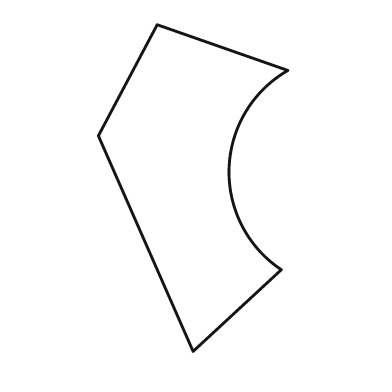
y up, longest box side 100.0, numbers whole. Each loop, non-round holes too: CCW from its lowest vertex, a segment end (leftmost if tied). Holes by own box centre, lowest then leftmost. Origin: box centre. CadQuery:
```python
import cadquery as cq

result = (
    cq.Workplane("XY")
    .moveTo(0.0, -50.0)
    .lineTo(27.0, -25.0)
    .threePointArc((11.0, 6.0), (29.0, 36.0))
    .lineTo(-11.0, 50.0)
    .lineTo(-29.0, 16.0)
    .close()
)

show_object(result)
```